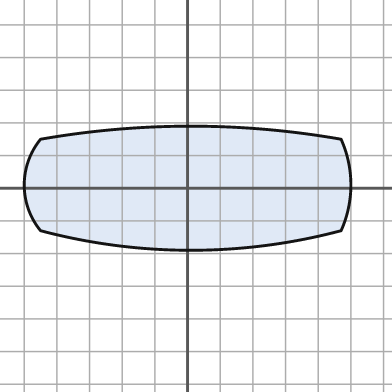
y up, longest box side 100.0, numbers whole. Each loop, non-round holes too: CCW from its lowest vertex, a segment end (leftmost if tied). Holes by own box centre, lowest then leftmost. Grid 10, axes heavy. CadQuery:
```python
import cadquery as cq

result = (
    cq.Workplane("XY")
    .moveTo(-45.0, -13.0)
    .threePointArc((1.0, -19.0), (47.0, -13.0))
    .threePointArc((50.0, 1.0), (47.0, 15.0))
    .threePointArc((1.0, 19.0), (-45.0, 15.0))
    .threePointArc((-50.0, 1.0), (-45.0, -13.0))
    .close()
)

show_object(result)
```